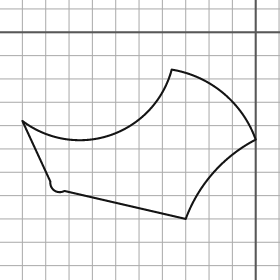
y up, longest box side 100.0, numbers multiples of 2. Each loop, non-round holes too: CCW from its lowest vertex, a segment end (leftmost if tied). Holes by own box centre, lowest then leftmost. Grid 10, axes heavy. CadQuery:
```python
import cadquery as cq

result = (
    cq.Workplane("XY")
    .moveTo(-30.0, -80.0)
    .threePointArc((-18.0, -60.0), (0.0, -46.0))
    .threePointArc((-14.0, -26.0), (-36.0, -16.0))
    .threePointArc((-62.0, -44.0), (-100.0, -38.0))
    .lineTo(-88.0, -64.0)
    .threePointArc((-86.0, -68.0), (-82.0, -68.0))
    .close()
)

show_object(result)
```